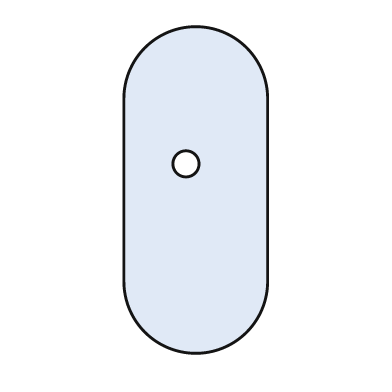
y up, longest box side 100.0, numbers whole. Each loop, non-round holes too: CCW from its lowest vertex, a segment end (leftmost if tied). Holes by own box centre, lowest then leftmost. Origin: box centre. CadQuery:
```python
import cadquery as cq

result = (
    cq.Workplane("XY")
    .moveTo(-22.0, -28.0)
    .threePointArc((0.0, -50.0), (22.0, -28.0))
    .lineTo(22.0, 28.0)
    .threePointArc((0.0, 50.0), (-22.0, 28.0))
    .close()
    .moveTo(-3.0, 8.0)
    .circle(4.0)
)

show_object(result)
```